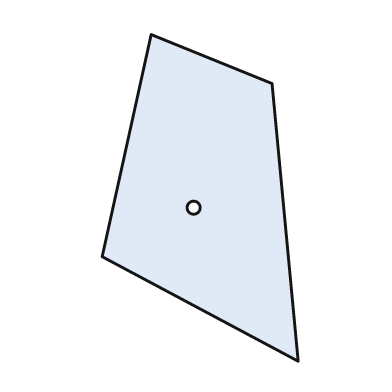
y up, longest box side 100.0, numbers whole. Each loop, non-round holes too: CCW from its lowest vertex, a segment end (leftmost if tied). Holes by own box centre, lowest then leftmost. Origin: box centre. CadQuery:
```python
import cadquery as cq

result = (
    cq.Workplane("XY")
    .moveTo(30.0, -50.0)
    .lineTo(22.0, 35.0)
    .lineTo(-15.0, 50.0)
    .lineTo(-30.0, -18.0)
    .close()
    .moveTo(-2.0, -3.0)
    .circle(2.0)
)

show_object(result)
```